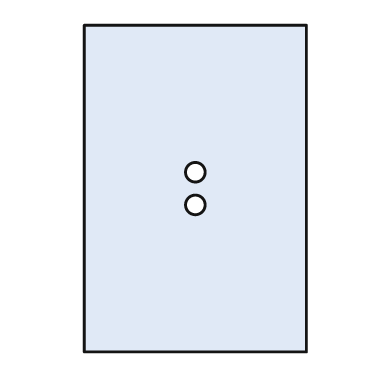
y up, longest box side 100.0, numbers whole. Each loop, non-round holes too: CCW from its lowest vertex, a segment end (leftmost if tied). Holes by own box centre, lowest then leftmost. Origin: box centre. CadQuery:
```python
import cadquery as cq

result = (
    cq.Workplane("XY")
    .moveTo(-34.0, -50.0)
    .lineTo(34.0, -50.0)
    .lineTo(34.0, 50.0)
    .lineTo(-34.0, 50.0)
    .close()
    .moveTo(0.0, -5.0)
    .circle(3.0)
    .moveTo(0.0, 5.0)
    .circle(3.0)
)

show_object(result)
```